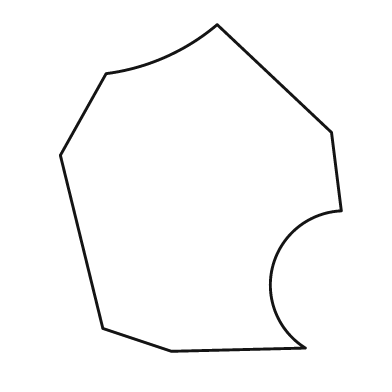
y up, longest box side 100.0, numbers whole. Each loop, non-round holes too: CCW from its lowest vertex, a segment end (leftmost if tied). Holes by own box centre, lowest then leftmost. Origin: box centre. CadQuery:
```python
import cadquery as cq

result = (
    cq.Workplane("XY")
    .moveTo(-9.0, -50.0)
    .lineTo(32.0, -49.0)
    .threePointArc((22.0, -24.0), (43.0, -7.0))
    .lineTo(40.0, 17.0)
    .lineTo(5.0, 50.0)
    .threePointArc((-11.0, 40.0), (-29.0, 35.0))
    .lineTo(-43.0, 10.0)
    .lineTo(-30.0, -43.0)
    .close()
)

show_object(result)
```